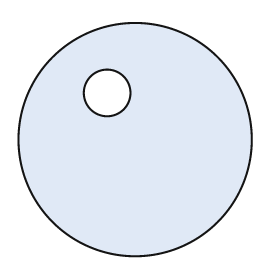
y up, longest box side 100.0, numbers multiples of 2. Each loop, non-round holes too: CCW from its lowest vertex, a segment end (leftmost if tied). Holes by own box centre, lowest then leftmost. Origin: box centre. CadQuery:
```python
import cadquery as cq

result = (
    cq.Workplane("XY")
    .moveTo(0.0, 0.0)
    .circle(50.0)
    .moveTo(-12.0, 20.0)
    .circle(10.0)
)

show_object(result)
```